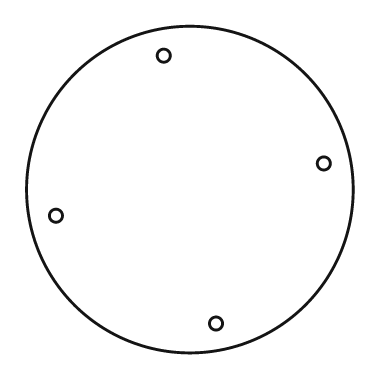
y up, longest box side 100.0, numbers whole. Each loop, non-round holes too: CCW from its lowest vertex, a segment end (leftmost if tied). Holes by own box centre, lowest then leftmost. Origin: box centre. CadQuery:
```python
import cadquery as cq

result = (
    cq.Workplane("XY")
    .moveTo(0.0, 0.0)
    .circle(50.0)
    .moveTo(8.0, -41.0)
    .circle(2.0)
    .moveTo(-41.0, -8.0)
    .circle(2.0)
    .moveTo(41.0, 8.0)
    .circle(2.0)
    .moveTo(-8.0, 41.0)
    .circle(2.0)
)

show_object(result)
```